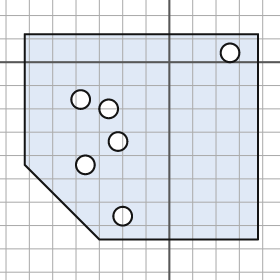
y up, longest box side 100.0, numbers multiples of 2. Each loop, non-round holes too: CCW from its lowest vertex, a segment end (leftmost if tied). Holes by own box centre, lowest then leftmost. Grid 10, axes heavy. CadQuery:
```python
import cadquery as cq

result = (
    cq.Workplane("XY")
    .moveTo(-30.0, -76.0)
    .lineTo(38.0, -76.0)
    .lineTo(38.0, 12.0)
    .lineTo(-62.0, 12.0)
    .lineTo(-62.0, -44.0)
    .close()
    .moveTo(-20.0, -66.0)
    .circle(4.0)
    .moveTo(-36.0, -44.0)
    .circle(4.0)
    .moveTo(-22.0, -34.0)
    .circle(4.0)
    .moveTo(-26.0, -20.0)
    .circle(4.0)
    .moveTo(-38.0, -16.0)
    .circle(4.0)
    .moveTo(26.0, 4.0)
    .circle(4.0)
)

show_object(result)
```